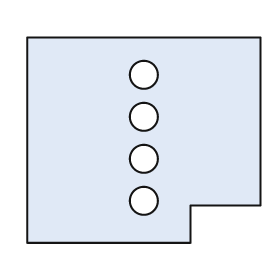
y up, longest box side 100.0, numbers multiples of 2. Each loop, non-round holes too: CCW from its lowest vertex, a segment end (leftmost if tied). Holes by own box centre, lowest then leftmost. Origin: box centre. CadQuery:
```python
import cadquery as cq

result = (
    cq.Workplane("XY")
    .moveTo(-50.0, -44.0)
    .lineTo(20.0, -44.0)
    .lineTo(20.0, -28.0)
    .lineTo(50.0, -28.0)
    .lineTo(50.0, 44.0)
    .lineTo(-50.0, 44.0)
    .close()
    .moveTo(0.0, -26.0)
    .circle(6.0)
    .moveTo(0.0, -8.0)
    .circle(6.0)
    .moveTo(0.0, 10.0)
    .circle(6.0)
    .moveTo(0.0, 28.0)
    .circle(6.0)
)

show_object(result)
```